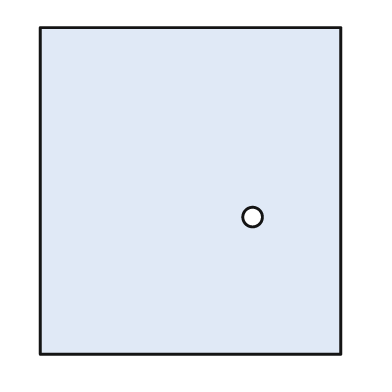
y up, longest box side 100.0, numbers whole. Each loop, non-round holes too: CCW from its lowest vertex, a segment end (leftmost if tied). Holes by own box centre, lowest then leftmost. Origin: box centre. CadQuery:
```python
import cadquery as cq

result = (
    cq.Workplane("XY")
    .moveTo(-46.0, -50.0)
    .lineTo(46.0, -50.0)
    .lineTo(46.0, 50.0)
    .lineTo(-46.0, 50.0)
    .close()
    .moveTo(19.0, -8.0)
    .circle(3.0)
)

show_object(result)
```